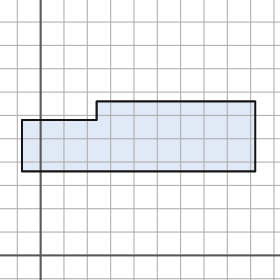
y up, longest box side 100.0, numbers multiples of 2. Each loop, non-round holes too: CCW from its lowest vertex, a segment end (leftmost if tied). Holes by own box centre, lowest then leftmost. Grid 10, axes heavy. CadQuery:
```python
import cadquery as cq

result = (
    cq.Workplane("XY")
    .moveTo(-8.0, 36.0)
    .lineTo(92.0, 36.0)
    .lineTo(92.0, 66.0)
    .lineTo(24.0, 66.0)
    .lineTo(24.0, 58.0)
    .lineTo(-8.0, 58.0)
    .close()
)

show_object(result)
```